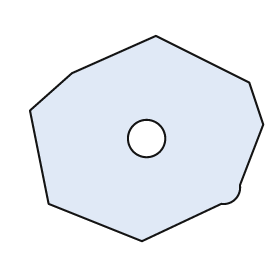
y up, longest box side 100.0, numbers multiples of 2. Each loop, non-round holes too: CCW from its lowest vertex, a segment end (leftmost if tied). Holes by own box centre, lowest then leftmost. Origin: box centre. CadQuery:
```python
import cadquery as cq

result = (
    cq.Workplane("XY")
    .moveTo(-2.0, -44.0)
    .lineTo(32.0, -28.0)
    .threePointArc((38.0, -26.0), (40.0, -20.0))
    .lineTo(50.0, 6.0)
    .lineTo(44.0, 24.0)
    .lineTo(4.0, 44.0)
    .lineTo(-32.0, 28.0)
    .lineTo(-50.0, 12.0)
    .lineTo(-42.0, -28.0)
    .close()
    .moveTo(0.0, 0.0)
    .circle(8.0)
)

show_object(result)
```